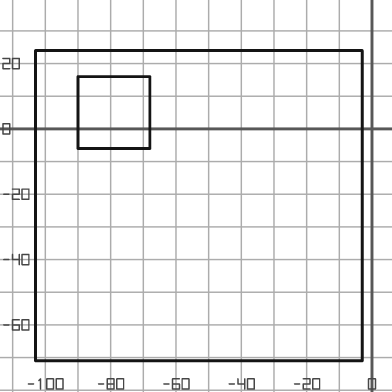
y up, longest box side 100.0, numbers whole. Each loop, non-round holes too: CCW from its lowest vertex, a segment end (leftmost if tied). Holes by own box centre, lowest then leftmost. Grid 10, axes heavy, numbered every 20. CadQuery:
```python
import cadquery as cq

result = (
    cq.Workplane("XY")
    .moveTo(-103.0, -71.0)
    .lineTo(-3.0, -71.0)
    .lineTo(-3.0, 24.0)
    .lineTo(-103.0, 24.0)
    .close()
    .moveTo(-90.0, -6.0)
    .lineTo(-68.0, -6.0)
    .lineTo(-68.0, 16.0)
    .lineTo(-90.0, 16.0)
    .close()
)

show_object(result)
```